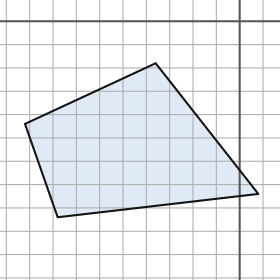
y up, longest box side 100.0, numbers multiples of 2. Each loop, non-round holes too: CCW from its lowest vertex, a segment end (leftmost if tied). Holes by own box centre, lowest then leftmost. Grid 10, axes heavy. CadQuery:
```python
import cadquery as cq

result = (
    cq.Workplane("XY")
    .moveTo(-78.0, -84.0)
    .lineTo(8.0, -74.0)
    .lineTo(-36.0, -18.0)
    .lineTo(-92.0, -44.0)
    .close()
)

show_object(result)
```